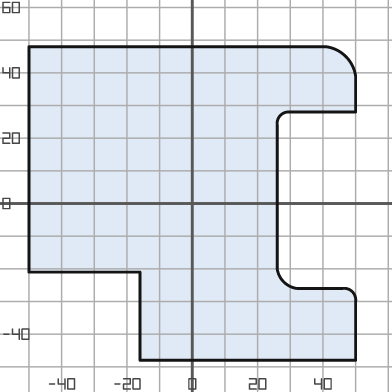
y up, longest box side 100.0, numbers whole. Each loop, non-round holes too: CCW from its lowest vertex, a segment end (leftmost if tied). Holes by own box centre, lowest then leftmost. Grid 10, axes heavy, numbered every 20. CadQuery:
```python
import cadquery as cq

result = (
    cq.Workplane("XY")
    .moveTo(-16.0, -48.0)
    .lineTo(50.0, -48.0)
    .lineTo(50.0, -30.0)
    .threePointArc((49.0, -27.0), (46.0, -26.0))
    .lineTo(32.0, -26.0)
    .threePointArc((28.0, -24.0), (26.0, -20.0))
    .lineTo(26.0, 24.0)
    .threePointArc((27.0, 27.0), (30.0, 28.0))
    .lineTo(50.0, 28.0)
    .lineTo(50.0, 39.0)
    .threePointArc((47.0, 45.0), (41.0, 48.0))
    .lineTo(-50.0, 48.0)
    .lineTo(-50.0, -21.0)
    .lineTo(-16.0, -21.0)
    .close()
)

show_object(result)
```